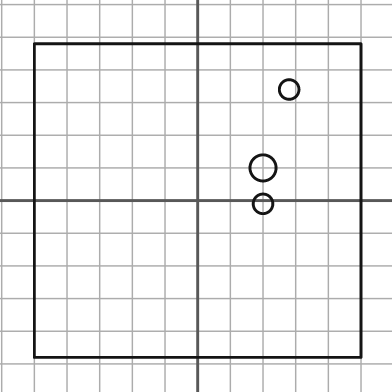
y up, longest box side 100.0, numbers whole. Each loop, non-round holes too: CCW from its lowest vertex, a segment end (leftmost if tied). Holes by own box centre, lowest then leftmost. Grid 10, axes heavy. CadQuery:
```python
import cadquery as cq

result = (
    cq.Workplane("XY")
    .moveTo(-50.0, -48.0)
    .lineTo(50.0, -48.0)
    .lineTo(50.0, 48.0)
    .lineTo(-50.0, 48.0)
    .close()
    .moveTo(20.0, -1.0)
    .circle(3.0)
    .moveTo(20.0, 10.0)
    .circle(4.0)
    .moveTo(28.0, 34.0)
    .circle(3.0)
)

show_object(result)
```